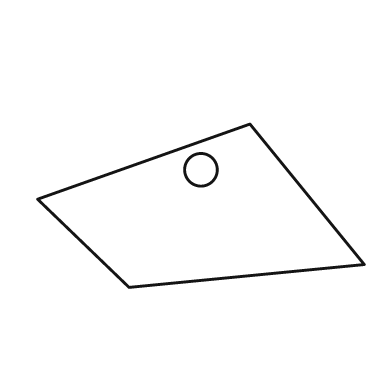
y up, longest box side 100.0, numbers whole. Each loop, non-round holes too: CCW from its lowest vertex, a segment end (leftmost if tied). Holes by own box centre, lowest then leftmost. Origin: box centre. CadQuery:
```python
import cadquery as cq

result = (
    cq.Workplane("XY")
    .moveTo(-22.0, -25.0)
    .lineTo(50.0, -18.0)
    .lineTo(15.0, 25.0)
    .lineTo(-50.0, 2.0)
    .close()
    .moveTo(0.0, 11.0)
    .circle(5.0)
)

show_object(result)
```